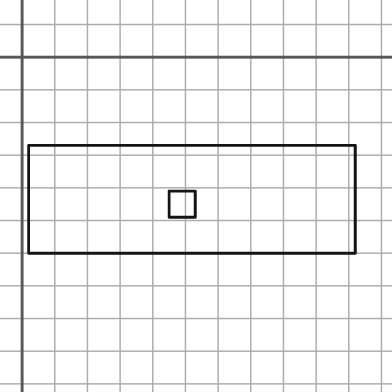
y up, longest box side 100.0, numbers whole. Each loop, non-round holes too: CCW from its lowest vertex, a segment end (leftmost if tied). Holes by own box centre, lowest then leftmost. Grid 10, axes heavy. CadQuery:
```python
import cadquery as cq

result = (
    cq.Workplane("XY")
    .moveTo(2.0, -60.0)
    .lineTo(102.0, -60.0)
    .lineTo(102.0, -27.0)
    .lineTo(2.0, -27.0)
    .close()
    .moveTo(45.0, -49.0)
    .lineTo(53.0, -49.0)
    .lineTo(53.0, -41.0)
    .lineTo(45.0, -41.0)
    .close()
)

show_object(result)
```